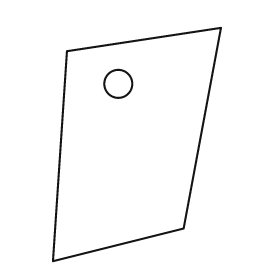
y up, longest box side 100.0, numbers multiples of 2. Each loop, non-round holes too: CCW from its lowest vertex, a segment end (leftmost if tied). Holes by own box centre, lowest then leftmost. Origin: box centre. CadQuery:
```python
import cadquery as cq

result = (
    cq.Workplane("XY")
    .moveTo(-36.0, -50.0)
    .lineTo(20.0, -36.0)
    .lineTo(36.0, 50.0)
    .lineTo(-30.0, 40.0)
    .close()
    .moveTo(-8.0, 26.0)
    .circle(6.0)
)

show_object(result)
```